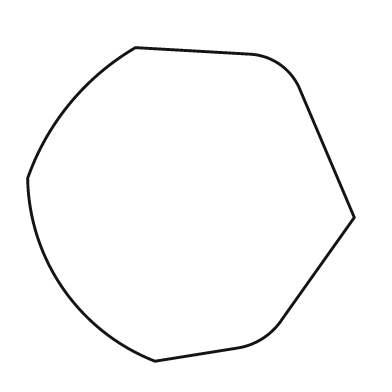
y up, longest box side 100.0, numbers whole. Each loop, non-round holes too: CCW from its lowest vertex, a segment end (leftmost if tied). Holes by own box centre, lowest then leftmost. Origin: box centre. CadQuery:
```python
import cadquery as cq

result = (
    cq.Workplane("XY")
    .moveTo(-11.0, -48.0)
    .lineTo(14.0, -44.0)
    .threePointArc((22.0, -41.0), (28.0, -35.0))
    .lineTo(50.0, -4.0)
    .lineTo(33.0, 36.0)
    .threePointArc((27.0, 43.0), (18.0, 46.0))
    .lineTo(-17.0, 48.0)
    .threePointArc((-37.0, 31.0), (-50.0, 8.0))
    .threePointArc((-39.0, -26.0), (-11.0, -48.0))
    .close()
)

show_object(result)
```